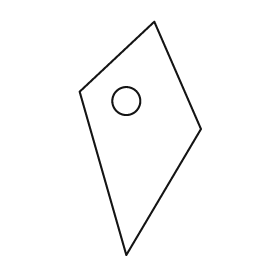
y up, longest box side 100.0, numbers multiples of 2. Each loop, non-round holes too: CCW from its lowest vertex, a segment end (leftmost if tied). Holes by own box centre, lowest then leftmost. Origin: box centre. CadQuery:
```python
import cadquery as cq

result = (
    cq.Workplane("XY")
    .moveTo(-6.0, -50.0)
    .lineTo(26.0, 4.0)
    .lineTo(6.0, 50.0)
    .lineTo(-26.0, 20.0)
    .close()
    .moveTo(-6.0, 16.0)
    .circle(6.0)
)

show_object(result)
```